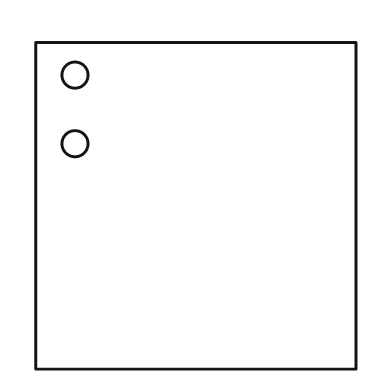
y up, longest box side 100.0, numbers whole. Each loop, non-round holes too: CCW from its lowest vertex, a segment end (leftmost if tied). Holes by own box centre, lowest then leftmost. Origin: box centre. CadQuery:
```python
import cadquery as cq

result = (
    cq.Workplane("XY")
    .moveTo(-49.0, -50.0)
    .lineTo(49.0, -50.0)
    .lineTo(49.0, 50.0)
    .lineTo(-49.0, 50.0)
    .close()
    .moveTo(-37.0, 19.0)
    .circle(4.0)
    .moveTo(-37.0, 40.0)
    .circle(4.0)
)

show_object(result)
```